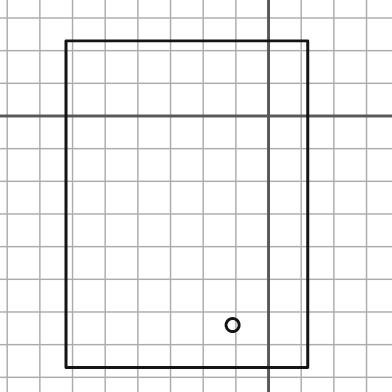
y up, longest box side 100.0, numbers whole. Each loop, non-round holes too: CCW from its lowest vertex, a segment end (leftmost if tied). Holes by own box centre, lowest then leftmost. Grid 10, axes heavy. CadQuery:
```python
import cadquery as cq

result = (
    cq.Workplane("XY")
    .moveTo(-62.0, -77.0)
    .lineTo(12.0, -77.0)
    .lineTo(12.0, 23.0)
    .lineTo(-62.0, 23.0)
    .close()
    .moveTo(-11.0, -64.0)
    .circle(2.0)
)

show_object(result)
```